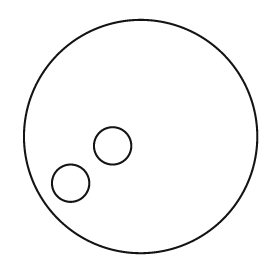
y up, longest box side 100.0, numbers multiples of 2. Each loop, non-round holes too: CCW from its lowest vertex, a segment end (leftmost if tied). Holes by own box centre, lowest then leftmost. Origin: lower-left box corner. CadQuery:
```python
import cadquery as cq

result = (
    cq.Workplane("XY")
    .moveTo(50.0, 50.0)
    .circle(50.0)
    .moveTo(20.0, 30.0)
    .circle(8.0)
    .moveTo(38.0, 46.0)
    .circle(8.0)
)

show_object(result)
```